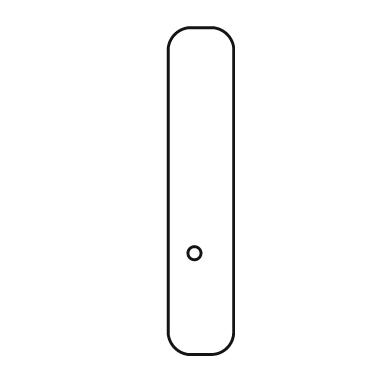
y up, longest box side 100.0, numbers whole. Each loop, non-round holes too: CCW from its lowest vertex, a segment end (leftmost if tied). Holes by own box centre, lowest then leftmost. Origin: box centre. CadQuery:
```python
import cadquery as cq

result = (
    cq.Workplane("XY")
    .moveTo(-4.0, -50.0)
    .lineTo(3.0, -50.0)
    .threePointArc((8.0, -48.0), (10.0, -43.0))
    .lineTo(10.0, 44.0)
    .threePointArc((8.0, 48.0), (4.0, 50.0))
    .lineTo(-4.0, 50.0)
    .threePointArc((-8.0, 48.0), (-10.0, 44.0))
    .lineTo(-10.0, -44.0)
    .threePointArc((-8.0, -48.0), (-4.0, -50.0))
    .close()
    .moveTo(-2.0, -19.0)
    .circle(2.0)
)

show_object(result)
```